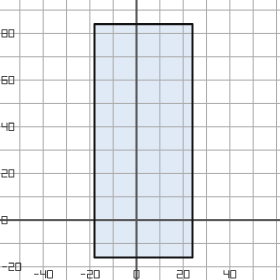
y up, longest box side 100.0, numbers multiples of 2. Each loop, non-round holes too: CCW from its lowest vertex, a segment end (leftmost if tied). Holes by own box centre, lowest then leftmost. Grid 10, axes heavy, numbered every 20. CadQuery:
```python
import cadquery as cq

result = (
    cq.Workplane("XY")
    .moveTo(-18.0, -16.0)
    .lineTo(24.0, -16.0)
    .lineTo(24.0, 84.0)
    .lineTo(-18.0, 84.0)
    .close()
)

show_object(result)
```